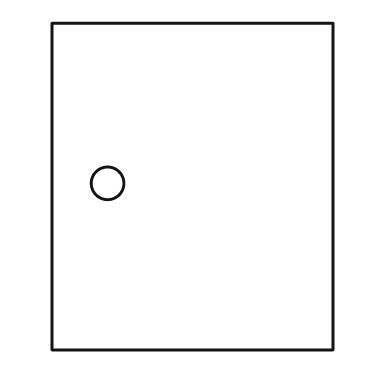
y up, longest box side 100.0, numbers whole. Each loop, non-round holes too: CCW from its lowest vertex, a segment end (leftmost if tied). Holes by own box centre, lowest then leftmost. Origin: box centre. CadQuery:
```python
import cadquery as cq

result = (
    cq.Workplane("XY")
    .moveTo(-43.0, -50.0)
    .lineTo(43.0, -50.0)
    .lineTo(43.0, 50.0)
    .lineTo(-43.0, 50.0)
    .close()
    .moveTo(-26.0, 1.0)
    .circle(5.0)
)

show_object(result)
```